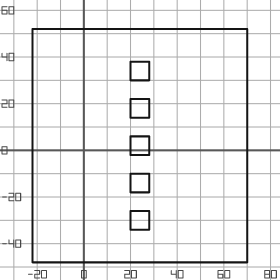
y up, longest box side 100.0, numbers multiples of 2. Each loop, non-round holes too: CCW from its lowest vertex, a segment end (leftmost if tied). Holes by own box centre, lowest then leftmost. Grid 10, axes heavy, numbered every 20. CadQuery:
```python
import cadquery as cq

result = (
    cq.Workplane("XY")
    .moveTo(-22.0, -48.0)
    .lineTo(70.0, -48.0)
    .lineTo(70.0, 52.0)
    .lineTo(-22.0, 52.0)
    .close()
    .moveTo(20.0, -34.0)
    .lineTo(28.0, -34.0)
    .lineTo(28.0, -26.0)
    .lineTo(20.0, -26.0)
    .close()
    .moveTo(20.0, -18.0)
    .lineTo(28.0, -18.0)
    .lineTo(28.0, -10.0)
    .lineTo(20.0, -10.0)
    .close()
    .moveTo(20.0, -2.0)
    .lineTo(28.0, -2.0)
    .lineTo(28.0, 6.0)
    .lineTo(20.0, 6.0)
    .close()
    .moveTo(20.0, 14.0)
    .lineTo(28.0, 14.0)
    .lineTo(28.0, 22.0)
    .lineTo(20.0, 22.0)
    .close()
    .moveTo(20.0, 30.0)
    .lineTo(28.0, 30.0)
    .lineTo(28.0, 38.0)
    .lineTo(20.0, 38.0)
    .close()
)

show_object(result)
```